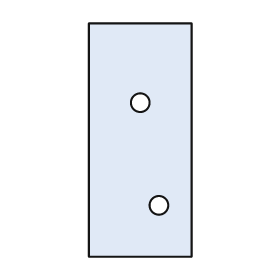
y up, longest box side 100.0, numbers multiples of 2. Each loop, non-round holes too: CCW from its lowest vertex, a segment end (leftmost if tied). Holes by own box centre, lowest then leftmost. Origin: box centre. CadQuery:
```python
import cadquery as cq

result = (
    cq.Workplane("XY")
    .moveTo(-22.0, -50.0)
    .lineTo(22.0, -50.0)
    .lineTo(22.0, 50.0)
    .lineTo(-22.0, 50.0)
    .close()
    .moveTo(8.0, -28.0)
    .circle(4.0)
    .moveTo(0.0, 16.0)
    .circle(4.0)
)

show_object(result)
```